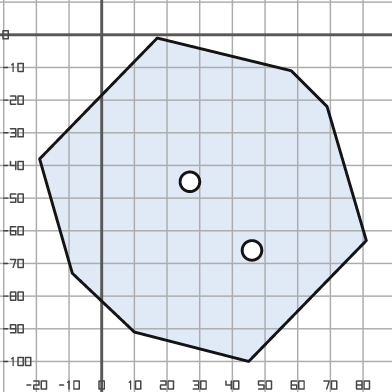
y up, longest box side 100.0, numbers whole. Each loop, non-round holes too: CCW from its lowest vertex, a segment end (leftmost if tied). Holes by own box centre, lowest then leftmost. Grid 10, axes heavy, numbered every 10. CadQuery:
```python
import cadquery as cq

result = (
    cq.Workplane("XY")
    .moveTo(45.0, -100.0)
    .lineTo(81.0, -63.0)
    .lineTo(69.0, -22.0)
    .lineTo(58.0, -11.0)
    .lineTo(17.0, -1.0)
    .lineTo(-19.0, -38.0)
    .lineTo(-9.0, -73.0)
    .lineTo(10.0, -91.0)
    .close()
    .moveTo(46.0, -66.0)
    .circle(3.0)
    .moveTo(27.0, -45.0)
    .circle(3.0)
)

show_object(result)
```